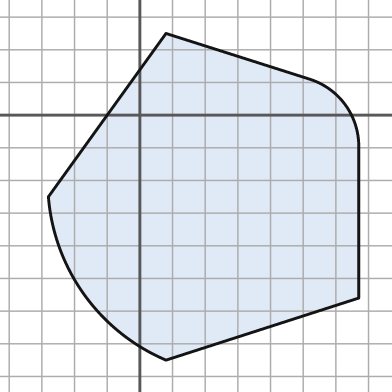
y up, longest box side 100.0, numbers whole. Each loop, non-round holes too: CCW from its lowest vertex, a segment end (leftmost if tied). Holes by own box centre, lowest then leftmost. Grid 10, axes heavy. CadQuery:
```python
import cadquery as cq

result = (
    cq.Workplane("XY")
    .moveTo(8.0, -75.0)
    .lineTo(67.0, -56.0)
    .lineTo(67.0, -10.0)
    .threePointArc((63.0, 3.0), (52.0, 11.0))
    .lineTo(8.0, 25.0)
    .lineTo(-28.0, -25.0)
    .threePointArc((-17.0, -55.0), (8.0, -75.0))
    .close()
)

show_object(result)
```